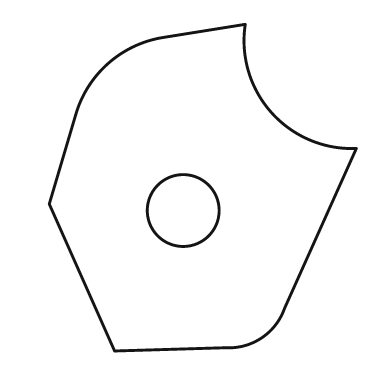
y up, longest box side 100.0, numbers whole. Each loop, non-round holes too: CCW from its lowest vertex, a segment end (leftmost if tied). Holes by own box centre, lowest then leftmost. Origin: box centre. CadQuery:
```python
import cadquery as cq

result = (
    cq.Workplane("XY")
    .moveTo(-27.0, -50.0)
    .lineTo(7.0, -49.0)
    .threePointArc((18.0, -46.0), (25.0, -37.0))
    .lineTo(47.0, 12.0)
    .threePointArc((21.0, 23.0), (13.0, 50.0))
    .lineTo(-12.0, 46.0)
    .threePointArc((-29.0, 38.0), (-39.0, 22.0))
    .lineTo(-47.0, -5.0)
    .close()
    .moveTo(-6.0, -7.0)
    .circle(11.0)
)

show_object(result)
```